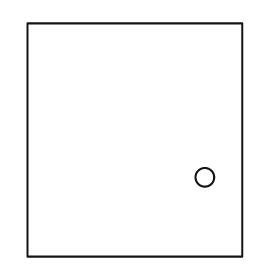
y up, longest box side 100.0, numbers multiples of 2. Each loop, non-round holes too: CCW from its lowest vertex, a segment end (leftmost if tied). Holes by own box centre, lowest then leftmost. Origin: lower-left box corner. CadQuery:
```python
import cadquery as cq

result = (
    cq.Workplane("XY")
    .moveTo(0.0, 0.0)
    .lineTo(92.0, 0.0)
    .lineTo(92.0, 100.0)
    .lineTo(0.0, 100.0)
    .close()
    .moveTo(76.0, 34.0)
    .circle(4.0)
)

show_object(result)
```